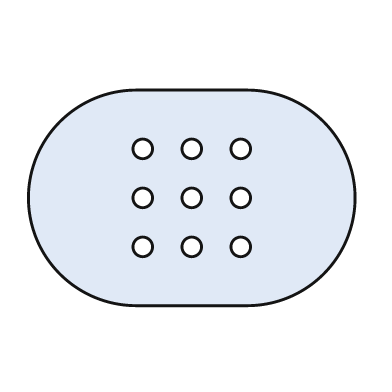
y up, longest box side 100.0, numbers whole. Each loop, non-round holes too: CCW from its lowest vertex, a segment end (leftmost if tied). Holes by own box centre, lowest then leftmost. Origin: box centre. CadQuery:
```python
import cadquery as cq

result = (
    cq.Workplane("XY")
    .moveTo(-17.0, -33.0)
    .lineTo(17.0, -33.0)
    .threePointArc((50.0, 0.0), (17.0, 33.0))
    .lineTo(-17.0, 33.0)
    .threePointArc((-50.0, 0.0), (-17.0, -33.0))
    .close()
    .moveTo(-15.0, -15.0)
    .circle(3.0)
    .moveTo(0.0, -15.0)
    .circle(3.0)
    .moveTo(15.0, -15.0)
    .circle(3.0)
    .moveTo(-15.0, 0.0)
    .circle(3.0)
    .moveTo(0.0, 0.0)
    .circle(3.0)
    .moveTo(15.0, 0.0)
    .circle(3.0)
    .moveTo(-15.0, 15.0)
    .circle(3.0)
    .moveTo(0.0, 15.0)
    .circle(3.0)
    .moveTo(15.0, 15.0)
    .circle(3.0)
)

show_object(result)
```